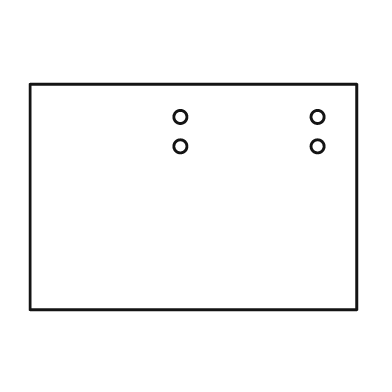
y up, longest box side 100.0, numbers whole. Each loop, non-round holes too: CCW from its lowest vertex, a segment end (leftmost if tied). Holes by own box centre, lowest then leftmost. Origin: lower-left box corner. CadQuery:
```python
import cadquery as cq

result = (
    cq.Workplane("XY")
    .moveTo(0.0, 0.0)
    .lineTo(100.0, 0.0)
    .lineTo(100.0, 69.0)
    .lineTo(0.0, 69.0)
    .close()
    .moveTo(46.0, 50.0)
    .circle(2.0)
    .moveTo(88.0, 50.0)
    .circle(2.0)
    .moveTo(46.0, 59.0)
    .circle(2.0)
    .moveTo(88.0, 59.0)
    .circle(2.0)
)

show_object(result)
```